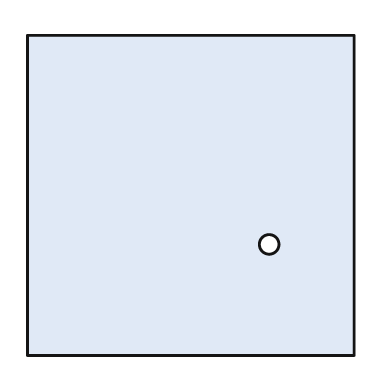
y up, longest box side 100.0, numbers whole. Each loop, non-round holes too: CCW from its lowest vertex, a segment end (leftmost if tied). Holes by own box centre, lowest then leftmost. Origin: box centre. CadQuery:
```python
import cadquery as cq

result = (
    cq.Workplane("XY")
    .moveTo(-50.0, -49.0)
    .lineTo(50.0, -49.0)
    .lineTo(50.0, 49.0)
    .lineTo(-50.0, 49.0)
    .close()
    .moveTo(24.0, -15.0)
    .circle(3.0)
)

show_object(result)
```